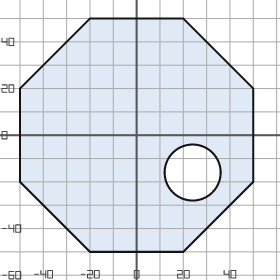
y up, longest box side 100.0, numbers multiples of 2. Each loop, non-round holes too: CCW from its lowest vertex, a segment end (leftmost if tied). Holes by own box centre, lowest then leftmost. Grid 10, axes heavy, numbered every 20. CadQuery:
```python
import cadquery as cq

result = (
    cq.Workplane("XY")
    .moveTo(-20.0, -50.0)
    .lineTo(20.0, -50.0)
    .lineTo(50.0, -20.0)
    .lineTo(50.0, 20.0)
    .lineTo(20.0, 50.0)
    .lineTo(-20.0, 50.0)
    .lineTo(-50.0, 20.0)
    .lineTo(-50.0, -20.0)
    .close()
    .moveTo(24.0, -16.0)
    .circle(12.0)
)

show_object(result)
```